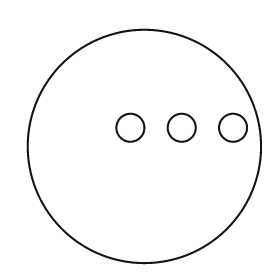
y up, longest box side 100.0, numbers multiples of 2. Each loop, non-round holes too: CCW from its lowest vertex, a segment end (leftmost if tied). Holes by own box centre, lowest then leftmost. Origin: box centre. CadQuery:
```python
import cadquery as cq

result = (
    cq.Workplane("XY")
    .moveTo(0.0, 0.0)
    .circle(50.0)
    .moveTo(-6.0, 8.0)
    .circle(6.0)
    .moveTo(16.0, 8.0)
    .circle(6.0)
    .moveTo(38.0, 8.0)
    .circle(6.0)
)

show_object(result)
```